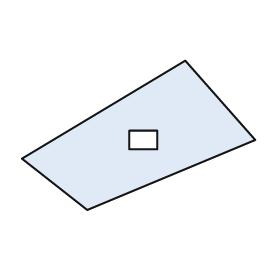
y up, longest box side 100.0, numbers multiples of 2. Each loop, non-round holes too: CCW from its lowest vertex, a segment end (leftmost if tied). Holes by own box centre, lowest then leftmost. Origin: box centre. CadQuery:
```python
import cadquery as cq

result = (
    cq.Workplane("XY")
    .moveTo(-22.0, -32.0)
    .lineTo(50.0, -2.0)
    .lineTo(20.0, 32.0)
    .lineTo(-50.0, -10.0)
    .close()
    .moveTo(-4.0, -6.0)
    .lineTo(8.0, -6.0)
    .lineTo(8.0, 2.0)
    .lineTo(-4.0, 2.0)
    .close()
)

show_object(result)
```